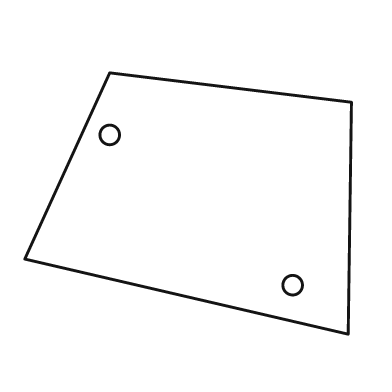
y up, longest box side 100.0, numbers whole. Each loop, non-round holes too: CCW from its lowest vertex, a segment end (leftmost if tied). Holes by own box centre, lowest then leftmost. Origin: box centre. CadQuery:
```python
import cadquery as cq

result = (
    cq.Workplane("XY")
    .moveTo(49.0, -40.0)
    .lineTo(50.0, 31.0)
    .lineTo(-24.0, 40.0)
    .lineTo(-50.0, -17.0)
    .close()
    .moveTo(32.0, -25.0)
    .circle(3.0)
    .moveTo(-24.0, 21.0)
    .circle(3.0)
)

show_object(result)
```